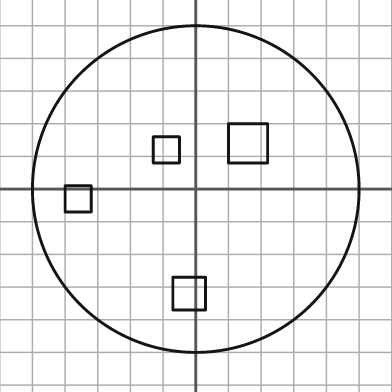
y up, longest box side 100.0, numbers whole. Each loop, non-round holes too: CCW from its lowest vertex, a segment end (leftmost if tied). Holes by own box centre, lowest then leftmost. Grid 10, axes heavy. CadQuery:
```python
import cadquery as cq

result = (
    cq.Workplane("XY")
    .moveTo(0.0, 0.0)
    .circle(50.0)
    .moveTo(-7.0, -37.0)
    .lineTo(3.0, -37.0)
    .lineTo(3.0, -27.0)
    .lineTo(-7.0, -27.0)
    .close()
    .moveTo(-40.0, -7.0)
    .lineTo(-32.0, -7.0)
    .lineTo(-32.0, 1.0)
    .lineTo(-40.0, 1.0)
    .close()
    .moveTo(-13.0, 8.0)
    .lineTo(-5.0, 8.0)
    .lineTo(-5.0, 16.0)
    .lineTo(-13.0, 16.0)
    .close()
    .moveTo(10.0, 8.0)
    .lineTo(22.0, 8.0)
    .lineTo(22.0, 20.0)
    .lineTo(10.0, 20.0)
    .close()
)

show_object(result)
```